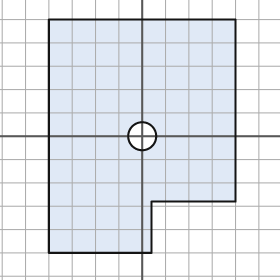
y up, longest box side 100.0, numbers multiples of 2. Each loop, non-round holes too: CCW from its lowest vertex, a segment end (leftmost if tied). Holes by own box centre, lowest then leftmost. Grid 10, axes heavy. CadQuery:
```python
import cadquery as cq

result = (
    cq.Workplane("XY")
    .moveTo(-40.0, -50.0)
    .lineTo(4.0, -50.0)
    .lineTo(4.0, -28.0)
    .lineTo(40.0, -28.0)
    .lineTo(40.0, 50.0)
    .lineTo(-40.0, 50.0)
    .close()
    .moveTo(0.0, 0.0)
    .circle(6.0)
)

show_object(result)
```